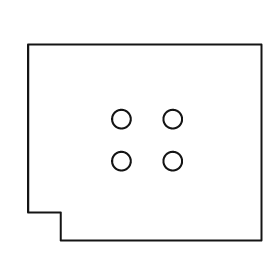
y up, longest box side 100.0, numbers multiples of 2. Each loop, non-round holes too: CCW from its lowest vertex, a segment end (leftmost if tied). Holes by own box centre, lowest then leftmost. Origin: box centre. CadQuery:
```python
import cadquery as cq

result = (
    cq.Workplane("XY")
    .moveTo(-36.0, -42.0)
    .lineTo(50.0, -42.0)
    .lineTo(50.0, 42.0)
    .lineTo(-50.0, 42.0)
    .lineTo(-50.0, -30.0)
    .lineTo(-36.0, -30.0)
    .close()
    .moveTo(-10.0, -8.0)
    .circle(4.0)
    .moveTo(12.0, -8.0)
    .circle(4.0)
    .moveTo(-10.0, 10.0)
    .circle(4.0)
    .moveTo(12.0, 10.0)
    .circle(4.0)
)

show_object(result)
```